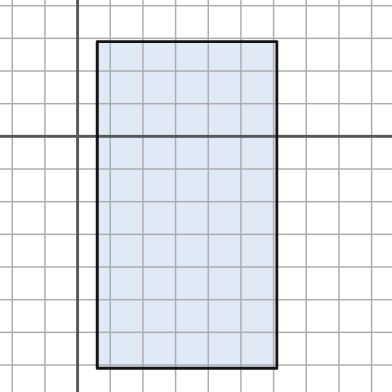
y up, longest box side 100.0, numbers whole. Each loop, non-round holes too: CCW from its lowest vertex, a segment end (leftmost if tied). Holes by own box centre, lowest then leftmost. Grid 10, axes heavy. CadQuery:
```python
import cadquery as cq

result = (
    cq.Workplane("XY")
    .moveTo(6.0, -71.0)
    .lineTo(61.0, -71.0)
    .lineTo(61.0, 29.0)
    .lineTo(6.0, 29.0)
    .close()
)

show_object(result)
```